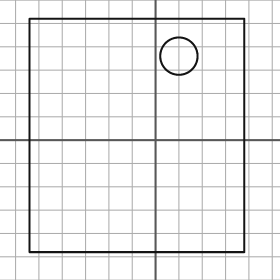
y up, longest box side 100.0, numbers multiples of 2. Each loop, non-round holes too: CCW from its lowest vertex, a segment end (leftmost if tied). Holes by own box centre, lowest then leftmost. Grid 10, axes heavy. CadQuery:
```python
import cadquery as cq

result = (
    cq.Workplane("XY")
    .moveTo(-54.0, -48.0)
    .lineTo(38.0, -48.0)
    .lineTo(38.0, 52.0)
    .lineTo(-54.0, 52.0)
    .close()
    .moveTo(10.0, 36.0)
    .circle(8.0)
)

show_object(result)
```